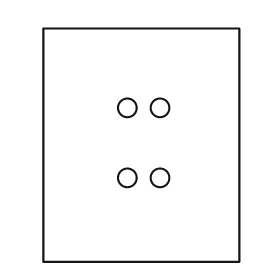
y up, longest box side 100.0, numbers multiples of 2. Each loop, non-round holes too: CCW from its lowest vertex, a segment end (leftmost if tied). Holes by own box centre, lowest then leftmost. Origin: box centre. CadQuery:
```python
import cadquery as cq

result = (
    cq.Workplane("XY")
    .moveTo(-42.0, -50.0)
    .lineTo(42.0, -50.0)
    .lineTo(42.0, 50.0)
    .lineTo(-42.0, 50.0)
    .close()
    .moveTo(-6.0, -14.0)
    .circle(4.0)
    .moveTo(8.0, -14.0)
    .circle(4.0)
    .moveTo(-6.0, 16.0)
    .circle(4.0)
    .moveTo(8.0, 16.0)
    .circle(4.0)
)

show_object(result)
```